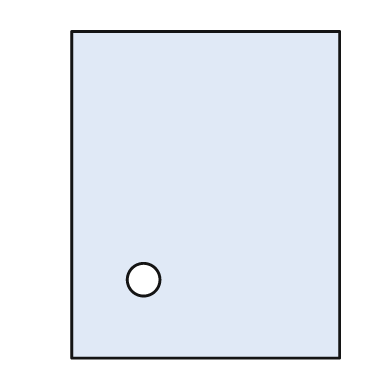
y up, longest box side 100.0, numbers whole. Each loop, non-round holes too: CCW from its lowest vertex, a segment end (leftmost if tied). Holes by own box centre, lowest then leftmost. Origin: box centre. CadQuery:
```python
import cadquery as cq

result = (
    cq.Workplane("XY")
    .moveTo(-41.0, -50.0)
    .lineTo(41.0, -50.0)
    .lineTo(41.0, 50.0)
    .lineTo(-41.0, 50.0)
    .close()
    .moveTo(-19.0, -26.0)
    .circle(5.0)
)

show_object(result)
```